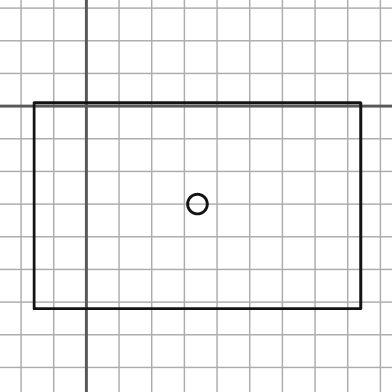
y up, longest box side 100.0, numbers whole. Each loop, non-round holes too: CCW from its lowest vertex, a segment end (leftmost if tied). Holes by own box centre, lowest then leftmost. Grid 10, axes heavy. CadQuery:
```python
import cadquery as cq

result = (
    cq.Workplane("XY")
    .moveTo(-16.0, -62.0)
    .lineTo(84.0, -62.0)
    .lineTo(84.0, 1.0)
    .lineTo(-16.0, 1.0)
    .close()
    .moveTo(34.0, -30.0)
    .circle(3.0)
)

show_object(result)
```